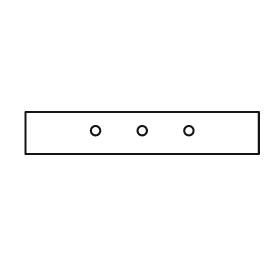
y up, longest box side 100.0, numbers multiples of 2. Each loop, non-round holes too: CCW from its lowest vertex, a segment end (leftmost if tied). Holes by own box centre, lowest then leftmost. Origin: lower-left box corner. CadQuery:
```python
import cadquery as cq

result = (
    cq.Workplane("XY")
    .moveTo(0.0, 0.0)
    .lineTo(100.0, 0.0)
    .lineTo(100.0, 18.0)
    .lineTo(0.0, 18.0)
    .close()
    .moveTo(30.0, 10.0)
    .circle(2.0)
    .moveTo(50.0, 10.0)
    .circle(2.0)
    .moveTo(70.0, 10.0)
    .circle(2.0)
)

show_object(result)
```